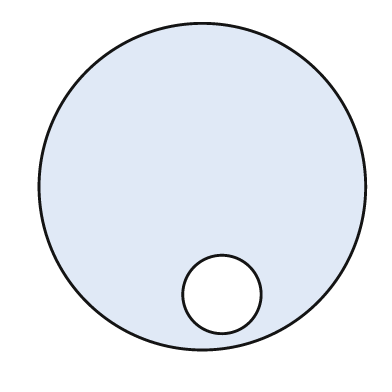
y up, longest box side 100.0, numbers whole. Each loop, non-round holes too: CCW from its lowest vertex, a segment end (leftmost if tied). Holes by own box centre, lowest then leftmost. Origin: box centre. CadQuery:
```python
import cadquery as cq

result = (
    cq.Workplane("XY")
    .moveTo(0.0, 0.0)
    .circle(50.0)
    .moveTo(6.0, -33.0)
    .circle(12.0)
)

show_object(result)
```